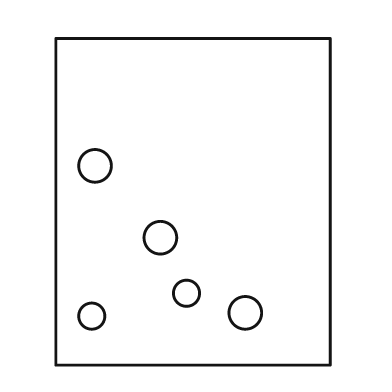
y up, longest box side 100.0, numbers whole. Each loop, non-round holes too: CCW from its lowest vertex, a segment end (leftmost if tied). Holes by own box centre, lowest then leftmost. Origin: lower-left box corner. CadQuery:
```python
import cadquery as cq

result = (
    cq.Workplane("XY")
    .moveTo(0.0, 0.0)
    .lineTo(84.0, 0.0)
    .lineTo(84.0, 100.0)
    .lineTo(0.0, 100.0)
    .close()
    .moveTo(11.0, 15.0)
    .circle(4.0)
    .moveTo(58.0, 16.0)
    .circle(5.0)
    .moveTo(40.0, 22.0)
    .circle(4.0)
    .moveTo(32.0, 39.0)
    .circle(5.0)
    .moveTo(12.0, 61.0)
    .circle(5.0)
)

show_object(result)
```